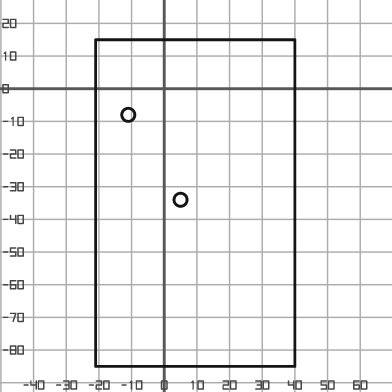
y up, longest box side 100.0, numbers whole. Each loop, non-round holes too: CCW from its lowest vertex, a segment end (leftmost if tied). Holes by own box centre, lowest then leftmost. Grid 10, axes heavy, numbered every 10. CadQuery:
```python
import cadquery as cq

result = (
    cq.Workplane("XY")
    .moveTo(-21.0, -85.0)
    .lineTo(40.0, -85.0)
    .lineTo(40.0, 15.0)
    .lineTo(-21.0, 15.0)
    .close()
    .moveTo(5.0, -34.0)
    .circle(2.0)
    .moveTo(-11.0, -8.0)
    .circle(2.0)
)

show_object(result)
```